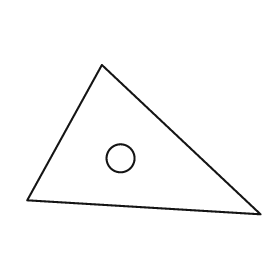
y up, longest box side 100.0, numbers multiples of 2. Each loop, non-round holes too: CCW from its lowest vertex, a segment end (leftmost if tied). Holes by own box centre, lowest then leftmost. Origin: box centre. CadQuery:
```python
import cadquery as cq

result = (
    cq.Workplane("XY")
    .moveTo(50.0, -32.0)
    .lineTo(-18.0, 32.0)
    .lineTo(-50.0, -26.0)
    .close()
    .moveTo(-10.0, -8.0)
    .circle(6.0)
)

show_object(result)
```